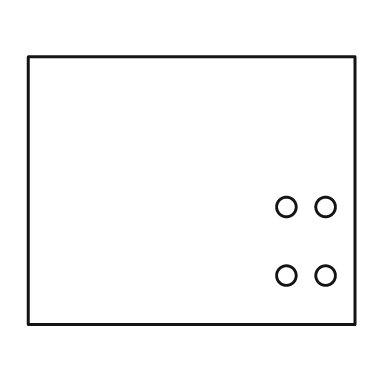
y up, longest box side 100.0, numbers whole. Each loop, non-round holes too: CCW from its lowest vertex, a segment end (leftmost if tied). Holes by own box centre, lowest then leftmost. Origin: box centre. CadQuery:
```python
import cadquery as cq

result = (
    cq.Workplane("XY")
    .moveTo(-50.0, -41.0)
    .lineTo(50.0, -41.0)
    .lineTo(50.0, 41.0)
    .lineTo(-50.0, 41.0)
    .close()
    .moveTo(29.0, -26.0)
    .circle(3.0)
    .moveTo(41.0, -26.0)
    .circle(3.0)
    .moveTo(29.0, -5.0)
    .circle(3.0)
    .moveTo(41.0, -5.0)
    .circle(3.0)
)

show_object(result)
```